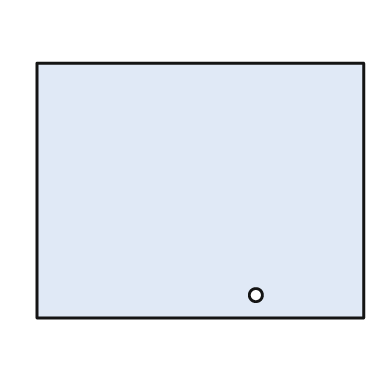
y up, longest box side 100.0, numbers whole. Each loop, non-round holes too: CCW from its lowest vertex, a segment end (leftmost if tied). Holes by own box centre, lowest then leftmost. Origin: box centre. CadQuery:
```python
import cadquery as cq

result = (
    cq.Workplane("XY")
    .moveTo(-50.0, -39.0)
    .lineTo(50.0, -39.0)
    .lineTo(50.0, 39.0)
    .lineTo(-50.0, 39.0)
    .close()
    .moveTo(17.0, -32.0)
    .circle(2.0)
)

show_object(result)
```